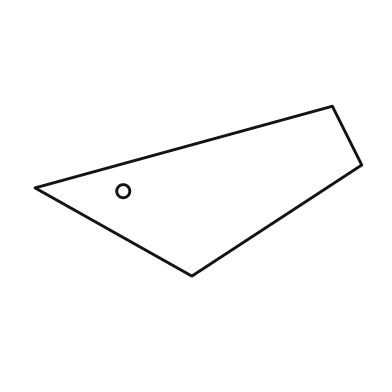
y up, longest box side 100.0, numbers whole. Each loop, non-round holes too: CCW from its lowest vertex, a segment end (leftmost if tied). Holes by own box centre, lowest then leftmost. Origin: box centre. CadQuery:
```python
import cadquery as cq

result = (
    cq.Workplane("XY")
    .moveTo(-2.0, -26.0)
    .lineTo(50.0, 8.0)
    .lineTo(41.0, 26.0)
    .lineTo(-50.0, 1.0)
    .close()
    .moveTo(-23.0, 0.0)
    .circle(2.0)
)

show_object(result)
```